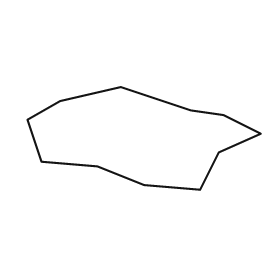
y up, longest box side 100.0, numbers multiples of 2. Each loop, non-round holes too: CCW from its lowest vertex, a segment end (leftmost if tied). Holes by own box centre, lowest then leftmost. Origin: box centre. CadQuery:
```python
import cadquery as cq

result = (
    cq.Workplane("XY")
    .moveTo(24.0, -22.0)
    .lineTo(32.0, -6.0)
    .lineTo(50.0, 2.0)
    .lineTo(34.0, 10.0)
    .lineTo(20.0, 12.0)
    .lineTo(-10.0, 22.0)
    .lineTo(-36.0, 16.0)
    .lineTo(-50.0, 8.0)
    .lineTo(-44.0, -10.0)
    .lineTo(-20.0, -12.0)
    .lineTo(0.0, -20.0)
    .close()
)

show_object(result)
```